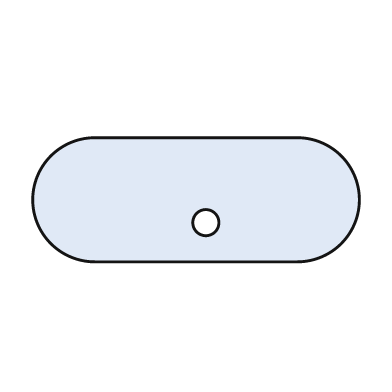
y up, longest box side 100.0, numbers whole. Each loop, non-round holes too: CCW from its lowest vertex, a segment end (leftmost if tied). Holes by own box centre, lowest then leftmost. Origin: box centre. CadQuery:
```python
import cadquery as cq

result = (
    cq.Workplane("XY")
    .moveTo(-31.0, -19.0)
    .lineTo(31.0, -19.0)
    .threePointArc((50.0, 0.0), (31.0, 19.0))
    .lineTo(-31.0, 19.0)
    .threePointArc((-50.0, 0.0), (-31.0, -19.0))
    .close()
    .moveTo(3.0, -7.0)
    .circle(4.0)
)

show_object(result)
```